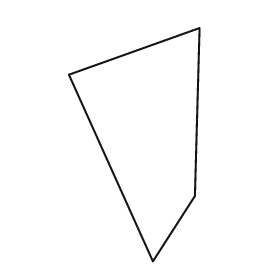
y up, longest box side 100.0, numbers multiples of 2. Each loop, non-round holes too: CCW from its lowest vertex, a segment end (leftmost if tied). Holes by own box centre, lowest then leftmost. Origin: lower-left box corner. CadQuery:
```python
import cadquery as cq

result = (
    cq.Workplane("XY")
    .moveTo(36.0, 0.0)
    .lineTo(54.0, 28.0)
    .lineTo(56.0, 100.0)
    .lineTo(0.0, 80.0)
    .close()
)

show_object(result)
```